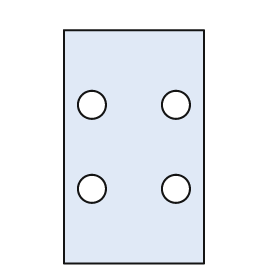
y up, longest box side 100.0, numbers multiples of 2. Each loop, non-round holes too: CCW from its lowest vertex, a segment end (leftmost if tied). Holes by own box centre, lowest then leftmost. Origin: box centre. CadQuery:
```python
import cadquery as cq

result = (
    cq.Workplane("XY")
    .moveTo(-30.0, -50.0)
    .lineTo(30.0, -50.0)
    .lineTo(30.0, 50.0)
    .lineTo(-30.0, 50.0)
    .close()
    .moveTo(-18.0, -18.0)
    .circle(6.0)
    .moveTo(18.0, -18.0)
    .circle(6.0)
    .moveTo(-18.0, 18.0)
    .circle(6.0)
    .moveTo(18.0, 18.0)
    .circle(6.0)
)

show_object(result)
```